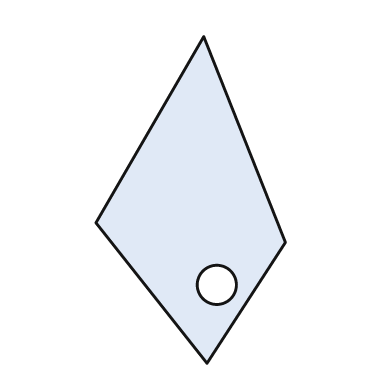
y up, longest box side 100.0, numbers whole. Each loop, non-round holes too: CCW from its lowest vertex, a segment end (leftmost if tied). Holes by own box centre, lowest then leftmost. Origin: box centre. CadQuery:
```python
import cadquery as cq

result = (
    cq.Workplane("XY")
    .moveTo(5.0, -50.0)
    .lineTo(29.0, -13.0)
    .lineTo(4.0, 50.0)
    .lineTo(-29.0, -7.0)
    .close()
    .moveTo(8.0, -26.0)
    .circle(6.0)
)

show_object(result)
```